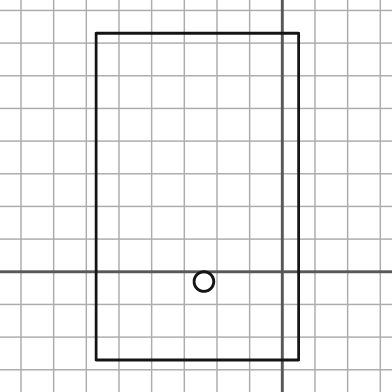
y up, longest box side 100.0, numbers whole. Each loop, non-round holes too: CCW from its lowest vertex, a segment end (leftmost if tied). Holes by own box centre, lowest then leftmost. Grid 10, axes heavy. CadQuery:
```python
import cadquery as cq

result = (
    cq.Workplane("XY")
    .moveTo(-57.0, -27.0)
    .lineTo(5.0, -27.0)
    .lineTo(5.0, 73.0)
    .lineTo(-57.0, 73.0)
    .close()
    .moveTo(-24.0, -3.0)
    .circle(3.0)
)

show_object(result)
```